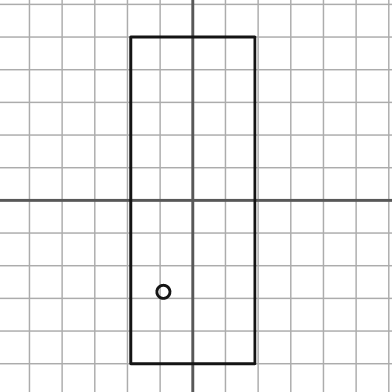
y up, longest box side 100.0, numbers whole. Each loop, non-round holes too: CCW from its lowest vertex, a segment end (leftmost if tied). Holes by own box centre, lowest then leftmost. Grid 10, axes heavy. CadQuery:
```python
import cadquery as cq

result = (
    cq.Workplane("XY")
    .moveTo(-19.0, -50.0)
    .lineTo(19.0, -50.0)
    .lineTo(19.0, 50.0)
    .lineTo(-19.0, 50.0)
    .close()
    .moveTo(-9.0, -28.0)
    .circle(2.0)
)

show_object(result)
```